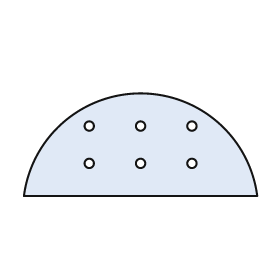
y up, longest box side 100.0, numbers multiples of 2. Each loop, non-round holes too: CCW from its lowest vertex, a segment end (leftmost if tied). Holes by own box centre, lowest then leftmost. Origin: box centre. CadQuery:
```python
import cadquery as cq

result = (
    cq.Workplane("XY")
    .moveTo(-50.0, -22.0)
    .lineTo(50.0, -22.0)
    .threePointArc((0.0, 22.0), (-50.0, -22.0))
    .close()
    .moveTo(-22.0, -8.0)
    .circle(2.0)
    .moveTo(0.0, -8.0)
    .circle(2.0)
    .moveTo(22.0, -8.0)
    .circle(2.0)
    .moveTo(-22.0, 8.0)
    .circle(2.0)
    .moveTo(0.0, 8.0)
    .circle(2.0)
    .moveTo(22.0, 8.0)
    .circle(2.0)
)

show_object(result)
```